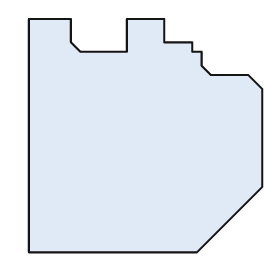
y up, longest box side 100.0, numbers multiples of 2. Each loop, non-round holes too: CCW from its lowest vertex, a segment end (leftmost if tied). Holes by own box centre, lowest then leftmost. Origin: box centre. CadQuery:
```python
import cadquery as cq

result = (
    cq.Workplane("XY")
    .moveTo(-50.0, -50.0)
    .lineTo(22.0, -50.0)
    .lineTo(50.0, -22.0)
    .lineTo(50.0, 20.0)
    .lineTo(44.0, 26.0)
    .lineTo(28.0, 26.0)
    .lineTo(24.0, 30.0)
    .lineTo(24.0, 36.0)
    .lineTo(20.0, 36.0)
    .lineTo(20.0, 40.0)
    .lineTo(8.0, 40.0)
    .lineTo(8.0, 50.0)
    .lineTo(-8.0, 50.0)
    .lineTo(-8.0, 36.0)
    .lineTo(-28.0, 36.0)
    .lineTo(-32.0, 40.0)
    .lineTo(-32.0, 50.0)
    .lineTo(-50.0, 50.0)
    .close()
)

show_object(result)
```